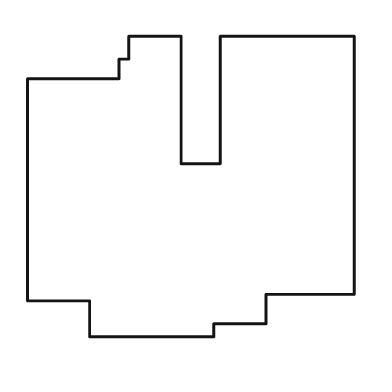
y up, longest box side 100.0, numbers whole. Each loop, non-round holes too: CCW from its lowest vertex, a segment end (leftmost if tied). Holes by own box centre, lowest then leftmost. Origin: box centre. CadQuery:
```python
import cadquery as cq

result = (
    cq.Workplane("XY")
    .moveTo(-31.0, -46.0)
    .lineTo(7.0, -46.0)
    .lineTo(7.0, -42.0)
    .lineTo(23.0, -42.0)
    .lineTo(23.0, -33.0)
    .lineTo(50.0, -33.0)
    .lineTo(50.0, 46.0)
    .lineTo(9.0, 46.0)
    .lineTo(9.0, 7.0)
    .lineTo(-3.0, 7.0)
    .lineTo(-3.0, 46.0)
    .lineTo(-19.0, 46.0)
    .lineTo(-19.0, 39.0)
    .lineTo(-22.0, 39.0)
    .lineTo(-22.0, 33.0)
    .lineTo(-50.0, 33.0)
    .lineTo(-50.0, -35.0)
    .lineTo(-31.0, -35.0)
    .close()
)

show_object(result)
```